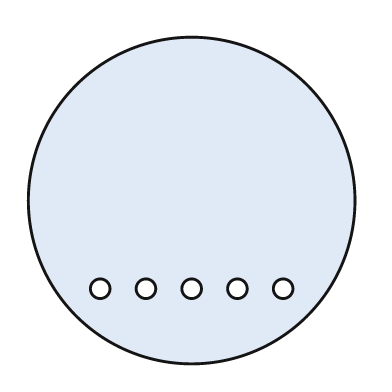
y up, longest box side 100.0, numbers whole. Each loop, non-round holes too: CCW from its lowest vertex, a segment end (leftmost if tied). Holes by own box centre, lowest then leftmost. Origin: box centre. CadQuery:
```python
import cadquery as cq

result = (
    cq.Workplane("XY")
    .moveTo(0.0, 0.0)
    .circle(50.0)
    .moveTo(-28.0, -27.0)
    .circle(3.0)
    .moveTo(-14.0, -27.0)
    .circle(3.0)
    .moveTo(0.0, -27.0)
    .circle(3.0)
    .moveTo(14.0, -27.0)
    .circle(3.0)
    .moveTo(28.0, -27.0)
    .circle(3.0)
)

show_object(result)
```